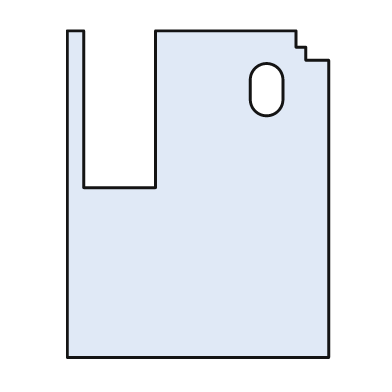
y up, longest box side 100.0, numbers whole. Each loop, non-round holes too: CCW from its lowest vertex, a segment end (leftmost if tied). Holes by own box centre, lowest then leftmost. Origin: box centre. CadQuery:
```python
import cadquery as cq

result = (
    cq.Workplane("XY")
    .moveTo(-40.0, -50.0)
    .lineTo(40.0, -50.0)
    .lineTo(40.0, 41.0)
    .lineTo(33.0, 41.0)
    .lineTo(33.0, 45.0)
    .lineTo(30.0, 45.0)
    .lineTo(30.0, 50.0)
    .lineTo(-13.0, 50.0)
    .lineTo(-13.0, 2.0)
    .lineTo(-35.0, 2.0)
    .lineTo(-35.0, 50.0)
    .lineTo(-40.0, 50.0)
    .close()
    .moveTo(16.0, 29.0)
    .threePointArc((21.0, 24.0), (26.0, 29.0))
    .lineTo(26.0, 35.0)
    .threePointArc((21.0, 40.0), (16.0, 35.0))
    .close()
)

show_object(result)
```